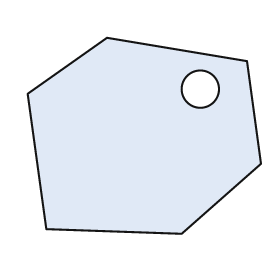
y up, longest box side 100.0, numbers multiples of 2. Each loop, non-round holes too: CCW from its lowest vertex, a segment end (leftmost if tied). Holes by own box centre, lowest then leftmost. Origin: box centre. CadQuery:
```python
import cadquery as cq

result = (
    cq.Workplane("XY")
    .moveTo(16.0, -42.0)
    .lineTo(50.0, -12.0)
    .lineTo(44.0, 32.0)
    .lineTo(-16.0, 42.0)
    .lineTo(-50.0, 18.0)
    .lineTo(-42.0, -40.0)
    .close()
    .moveTo(24.0, 20.0)
    .circle(8.0)
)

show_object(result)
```